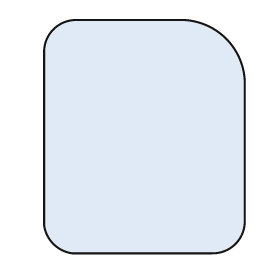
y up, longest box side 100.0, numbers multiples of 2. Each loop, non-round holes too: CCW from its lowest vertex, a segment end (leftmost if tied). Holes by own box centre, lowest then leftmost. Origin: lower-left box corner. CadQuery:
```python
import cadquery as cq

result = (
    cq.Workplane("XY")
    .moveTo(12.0, 0.0)
    .lineTo(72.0, 0.0)
    .threePointArc((82.0, 4.0), (86.0, 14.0))
    .lineTo(86.0, 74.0)
    .threePointArc((78.0, 92.0), (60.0, 100.0))
    .lineTo(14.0, 100.0)
    .threePointArc((4.0, 96.0), (0.0, 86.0))
    .lineTo(0.0, 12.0)
    .threePointArc((4.0, 4.0), (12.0, 0.0))
    .close()
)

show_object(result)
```